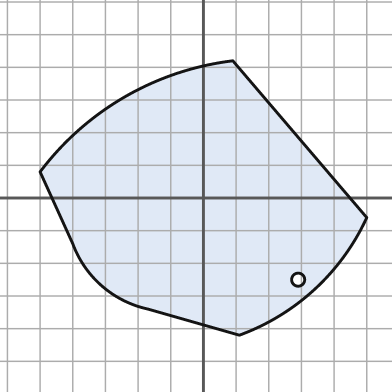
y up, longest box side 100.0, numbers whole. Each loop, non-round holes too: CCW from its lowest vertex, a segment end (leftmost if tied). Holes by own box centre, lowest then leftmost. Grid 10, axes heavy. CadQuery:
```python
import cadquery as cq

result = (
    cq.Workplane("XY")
    .moveTo(11.0, -42.0)
    .threePointArc((34.0, -28.0), (50.0, -6.0))
    .lineTo(9.0, 42.0)
    .threePointArc((-24.0, 31.0), (-50.0, 8.0))
    .lineTo(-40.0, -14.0)
    .threePointArc((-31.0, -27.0), (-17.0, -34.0))
    .close()
    .moveTo(29.0, -25.0)
    .circle(2.0)
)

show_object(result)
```